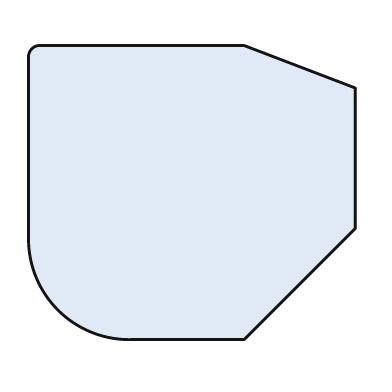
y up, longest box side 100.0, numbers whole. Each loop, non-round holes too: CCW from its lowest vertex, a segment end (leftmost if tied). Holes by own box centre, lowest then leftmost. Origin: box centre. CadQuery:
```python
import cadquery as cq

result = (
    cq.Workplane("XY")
    .moveTo(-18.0, -45.0)
    .lineTo(16.0, -45.0)
    .lineTo(50.0, -11.0)
    .lineTo(50.0, 32.0)
    .lineTo(16.0, 45.0)
    .lineTo(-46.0, 45.0)
    .threePointArc((-49.0, 44.0), (-50.0, 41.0))
    .lineTo(-50.0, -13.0)
    .threePointArc((-41.0, -36.0), (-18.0, -45.0))
    .close()
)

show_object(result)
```